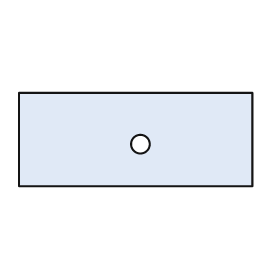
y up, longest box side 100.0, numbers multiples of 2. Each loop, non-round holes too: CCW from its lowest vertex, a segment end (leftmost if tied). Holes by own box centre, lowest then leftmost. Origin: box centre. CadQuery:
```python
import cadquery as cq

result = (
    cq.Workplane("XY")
    .moveTo(-50.0, -20.0)
    .lineTo(50.0, -20.0)
    .lineTo(50.0, 20.0)
    .lineTo(-50.0, 20.0)
    .close()
    .moveTo(2.0, -2.0)
    .circle(4.0)
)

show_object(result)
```